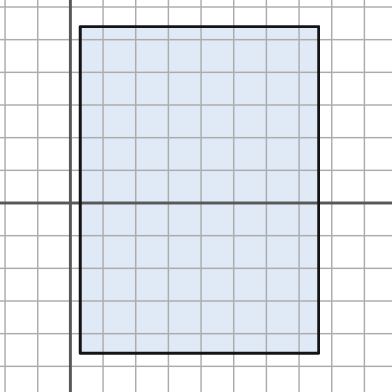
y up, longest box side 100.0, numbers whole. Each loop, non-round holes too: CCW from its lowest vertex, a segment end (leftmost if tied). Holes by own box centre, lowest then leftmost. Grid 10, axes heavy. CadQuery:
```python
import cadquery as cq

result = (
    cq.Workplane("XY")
    .moveTo(3.0, -46.0)
    .lineTo(76.0, -46.0)
    .lineTo(76.0, 54.0)
    .lineTo(3.0, 54.0)
    .close()
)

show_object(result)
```